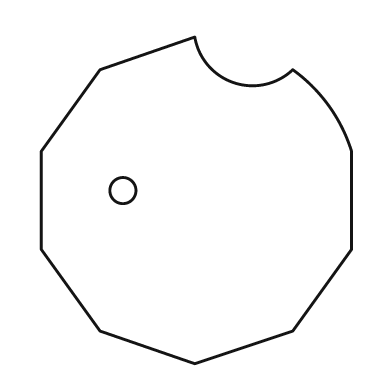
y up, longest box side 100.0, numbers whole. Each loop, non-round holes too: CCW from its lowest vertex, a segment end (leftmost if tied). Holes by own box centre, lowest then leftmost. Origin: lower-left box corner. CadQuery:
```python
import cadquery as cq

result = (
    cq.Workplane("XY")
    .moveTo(47.0, 0.0)
    .lineTo(77.0, 10.0)
    .lineTo(95.0, 35.0)
    .lineTo(95.0, 65.0)
    .threePointArc((88.0, 79.0), (77.0, 90.0))
    .threePointArc((59.0, 86.0), (47.0, 100.0))
    .lineTo(18.0, 90.0)
    .lineTo(0.0, 65.0)
    .lineTo(0.0, 35.0)
    .lineTo(18.0, 10.0)
    .close()
    .moveTo(25.0, 53.0)
    .circle(4.0)
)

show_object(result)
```